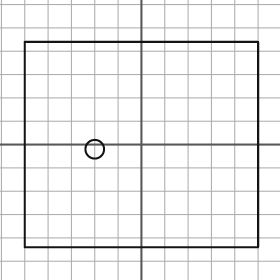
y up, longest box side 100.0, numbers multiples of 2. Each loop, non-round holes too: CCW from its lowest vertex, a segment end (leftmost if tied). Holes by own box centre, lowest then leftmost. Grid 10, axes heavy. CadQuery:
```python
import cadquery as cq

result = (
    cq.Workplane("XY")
    .moveTo(-50.0, -44.0)
    .lineTo(50.0, -44.0)
    .lineTo(50.0, 44.0)
    .lineTo(-50.0, 44.0)
    .close()
    .moveTo(-20.0, -2.0)
    .circle(4.0)
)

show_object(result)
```